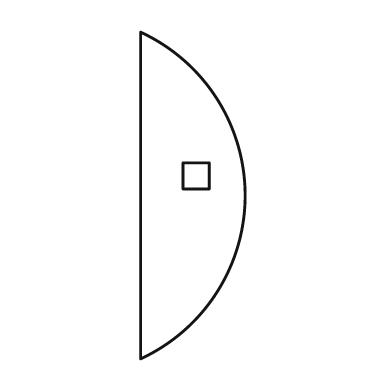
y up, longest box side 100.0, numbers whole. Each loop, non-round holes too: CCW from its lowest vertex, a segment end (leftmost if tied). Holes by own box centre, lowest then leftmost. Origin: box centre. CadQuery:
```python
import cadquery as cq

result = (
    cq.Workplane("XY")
    .moveTo(-16.0, -50.0)
    .threePointArc((16.0, 0.0), (-16.0, 50.0))
    .close()
    .moveTo(-3.0, 2.0)
    .lineTo(5.0, 2.0)
    .lineTo(5.0, 10.0)
    .lineTo(-3.0, 10.0)
    .close()
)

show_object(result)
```